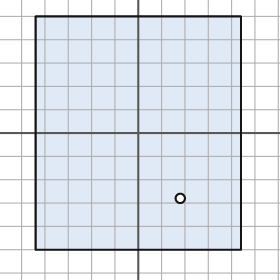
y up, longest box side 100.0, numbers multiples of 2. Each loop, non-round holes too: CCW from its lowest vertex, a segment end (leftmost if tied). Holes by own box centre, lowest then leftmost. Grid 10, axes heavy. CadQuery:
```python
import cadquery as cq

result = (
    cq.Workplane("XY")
    .moveTo(-44.0, -50.0)
    .lineTo(44.0, -50.0)
    .lineTo(44.0, 50.0)
    .lineTo(-44.0, 50.0)
    .close()
    .moveTo(18.0, -28.0)
    .circle(2.0)
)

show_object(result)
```